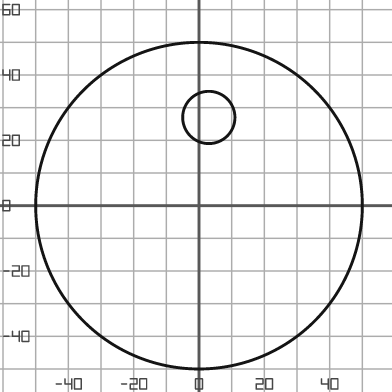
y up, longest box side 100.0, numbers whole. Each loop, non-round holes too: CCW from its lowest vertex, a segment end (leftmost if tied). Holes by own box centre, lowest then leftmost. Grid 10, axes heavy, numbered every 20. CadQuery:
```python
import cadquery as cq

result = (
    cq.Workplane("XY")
    .moveTo(0.0, 0.0)
    .circle(50.0)
    .moveTo(3.0, 27.0)
    .circle(8.0)
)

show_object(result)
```